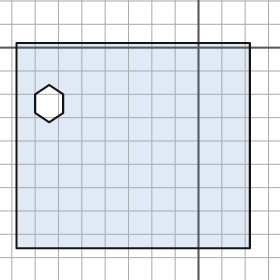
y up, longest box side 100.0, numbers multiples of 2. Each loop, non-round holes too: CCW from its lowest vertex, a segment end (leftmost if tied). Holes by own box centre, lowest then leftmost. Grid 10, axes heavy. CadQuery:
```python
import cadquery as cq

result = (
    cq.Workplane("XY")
    .moveTo(-78.0, -86.0)
    .lineTo(22.0, -86.0)
    .lineTo(22.0, 2.0)
    .lineTo(-78.0, 2.0)
    .close()
    .moveTo(-64.0, -32.0)
    .lineTo(-58.0, -28.0)
    .lineTo(-58.0, -20.0)
    .lineTo(-64.0, -16.0)
    .lineTo(-70.0, -20.0)
    .lineTo(-70.0, -28.0)
    .close()
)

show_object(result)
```